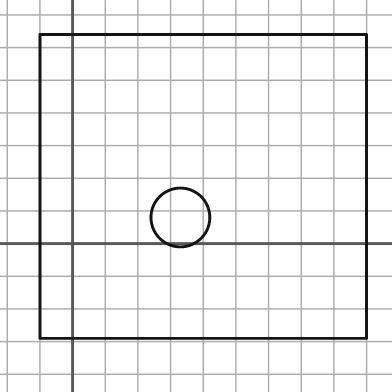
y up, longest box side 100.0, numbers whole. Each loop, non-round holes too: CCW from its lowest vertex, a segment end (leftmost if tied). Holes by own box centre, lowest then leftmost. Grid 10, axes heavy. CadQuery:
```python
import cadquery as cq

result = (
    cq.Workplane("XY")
    .moveTo(-10.0, -29.0)
    .lineTo(90.0, -29.0)
    .lineTo(90.0, 64.0)
    .lineTo(-10.0, 64.0)
    .close()
    .moveTo(33.0, 8.0)
    .circle(9.0)
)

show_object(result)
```